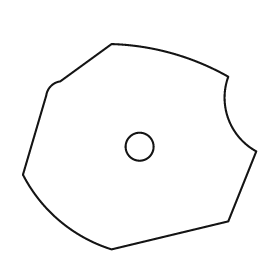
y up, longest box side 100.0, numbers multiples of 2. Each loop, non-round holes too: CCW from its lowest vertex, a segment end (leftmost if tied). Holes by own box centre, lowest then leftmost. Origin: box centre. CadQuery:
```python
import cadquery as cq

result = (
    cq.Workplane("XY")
    .moveTo(-12.0, -44.0)
    .lineTo(38.0, -32.0)
    .lineTo(50.0, -2.0)
    .threePointArc((38.0, 12.0), (38.0, 30.0))
    .threePointArc((14.0, 40.0), (-12.0, 44.0))
    .lineTo(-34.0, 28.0)
    .threePointArc((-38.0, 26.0), (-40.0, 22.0))
    .lineTo(-50.0, -12.0)
    .threePointArc((-34.0, -32.0), (-12.0, -44.0))
    .close()
    .moveTo(0.0, 0.0)
    .circle(6.0)
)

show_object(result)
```